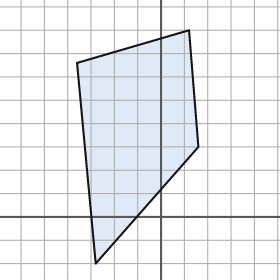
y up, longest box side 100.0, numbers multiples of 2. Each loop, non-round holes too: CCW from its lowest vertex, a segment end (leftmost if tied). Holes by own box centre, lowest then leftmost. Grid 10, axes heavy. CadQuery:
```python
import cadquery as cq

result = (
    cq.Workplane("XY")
    .moveTo(-28.0, -20.0)
    .lineTo(16.0, 30.0)
    .lineTo(12.0, 80.0)
    .lineTo(-36.0, 66.0)
    .close()
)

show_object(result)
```